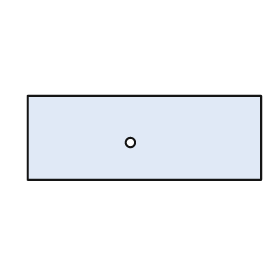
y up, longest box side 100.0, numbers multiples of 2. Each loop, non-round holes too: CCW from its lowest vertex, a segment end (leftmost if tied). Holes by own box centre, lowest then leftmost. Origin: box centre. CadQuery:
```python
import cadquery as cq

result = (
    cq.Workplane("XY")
    .moveTo(-50.0, -18.0)
    .lineTo(50.0, -18.0)
    .lineTo(50.0, 18.0)
    .lineTo(-50.0, 18.0)
    .close()
    .moveTo(-6.0, -2.0)
    .circle(2.0)
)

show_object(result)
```